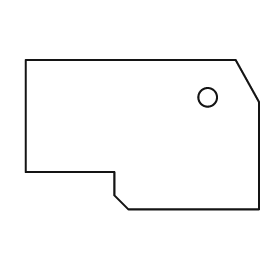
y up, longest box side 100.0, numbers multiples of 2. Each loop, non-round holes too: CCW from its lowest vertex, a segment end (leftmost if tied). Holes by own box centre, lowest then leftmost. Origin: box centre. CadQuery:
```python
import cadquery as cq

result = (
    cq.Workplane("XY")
    .moveTo(-6.0, -32.0)
    .lineTo(50.0, -32.0)
    .lineTo(50.0, 14.0)
    .lineTo(40.0, 32.0)
    .lineTo(-50.0, 32.0)
    .lineTo(-50.0, -16.0)
    .lineTo(-12.0, -16.0)
    .lineTo(-12.0, -26.0)
    .close()
    .moveTo(28.0, 16.0)
    .circle(4.0)
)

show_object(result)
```